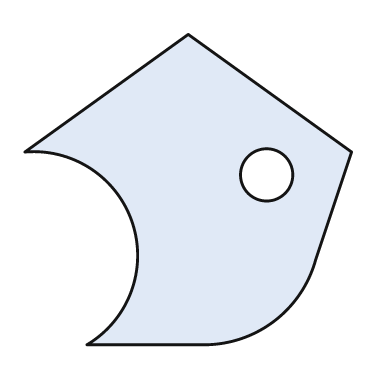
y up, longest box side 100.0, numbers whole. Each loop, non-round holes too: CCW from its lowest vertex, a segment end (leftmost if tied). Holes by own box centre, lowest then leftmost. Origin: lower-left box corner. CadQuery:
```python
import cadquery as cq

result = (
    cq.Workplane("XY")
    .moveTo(19.0, 0.0)
    .lineTo(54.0, 0.0)
    .threePointArc((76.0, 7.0), (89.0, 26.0))
    .lineTo(100.0, 59.0)
    .lineTo(50.0, 95.0)
    .lineTo(0.0, 59.0)
    .threePointArc((33.0, 37.0), (19.0, 0.0))
    .close()
    .moveTo(74.0, 52.0)
    .circle(8.0)
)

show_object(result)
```